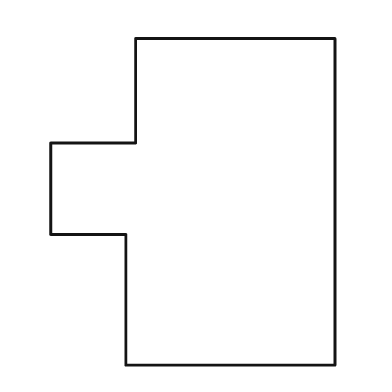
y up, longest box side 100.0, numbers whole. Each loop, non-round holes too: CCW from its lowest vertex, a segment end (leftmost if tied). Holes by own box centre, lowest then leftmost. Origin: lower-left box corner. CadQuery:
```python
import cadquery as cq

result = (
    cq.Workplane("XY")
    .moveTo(23.0, 0.0)
    .lineTo(87.0, 0.0)
    .lineTo(87.0, 100.0)
    .lineTo(26.0, 100.0)
    .lineTo(26.0, 68.0)
    .lineTo(0.0, 68.0)
    .lineTo(0.0, 40.0)
    .lineTo(23.0, 40.0)
    .close()
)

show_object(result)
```